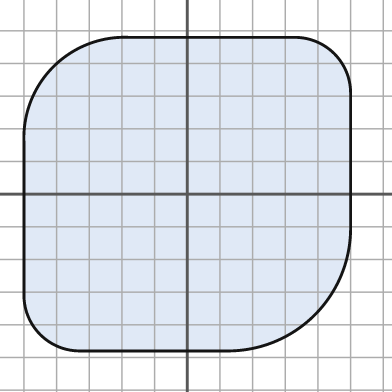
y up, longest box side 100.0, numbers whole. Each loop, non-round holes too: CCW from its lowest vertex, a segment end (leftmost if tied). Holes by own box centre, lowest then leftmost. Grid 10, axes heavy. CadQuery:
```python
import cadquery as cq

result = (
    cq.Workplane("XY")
    .moveTo(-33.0, -48.0)
    .lineTo(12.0, -48.0)
    .threePointArc((39.0, -37.0), (50.0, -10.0))
    .lineTo(50.0, 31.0)
    .threePointArc((45.0, 43.0), (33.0, 48.0))
    .lineTo(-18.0, 48.0)
    .threePointArc((-41.0, 39.0), (-50.0, 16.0))
    .lineTo(-50.0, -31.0)
    .threePointArc((-45.0, -43.0), (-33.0, -48.0))
    .close()
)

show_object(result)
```